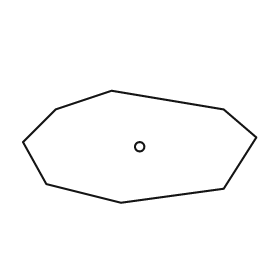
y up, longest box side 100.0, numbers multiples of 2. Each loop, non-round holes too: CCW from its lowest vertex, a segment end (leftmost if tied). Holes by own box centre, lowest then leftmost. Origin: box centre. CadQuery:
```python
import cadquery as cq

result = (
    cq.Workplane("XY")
    .moveTo(-8.0, -24.0)
    .lineTo(36.0, -18.0)
    .lineTo(50.0, 4.0)
    .lineTo(36.0, 16.0)
    .lineTo(-12.0, 24.0)
    .lineTo(-36.0, 16.0)
    .lineTo(-50.0, 2.0)
    .lineTo(-40.0, -16.0)
    .close()
    .moveTo(0.0, 0.0)
    .circle(2.0)
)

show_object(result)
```